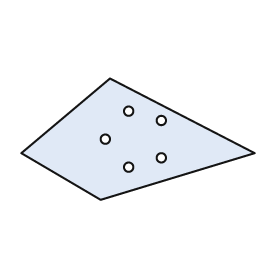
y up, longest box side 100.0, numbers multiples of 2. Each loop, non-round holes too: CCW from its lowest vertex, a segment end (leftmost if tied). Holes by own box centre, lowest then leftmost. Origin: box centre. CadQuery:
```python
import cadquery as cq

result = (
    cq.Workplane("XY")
    .moveTo(-16.0, -26.0)
    .lineTo(50.0, -6.0)
    .lineTo(-12.0, 26.0)
    .lineTo(-50.0, -6.0)
    .close()
    .moveTo(-4.0, -12.0)
    .circle(2.0)
    .moveTo(10.0, -8.0)
    .circle(2.0)
    .moveTo(-14.0, 0.0)
    .circle(2.0)
    .moveTo(10.0, 8.0)
    .circle(2.0)
    .moveTo(-4.0, 12.0)
    .circle(2.0)
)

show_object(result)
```